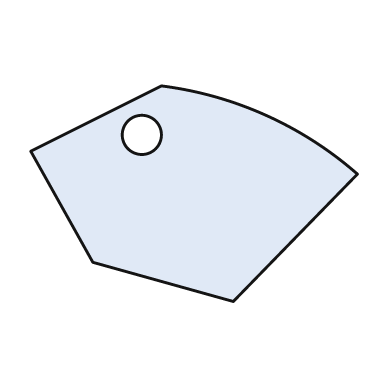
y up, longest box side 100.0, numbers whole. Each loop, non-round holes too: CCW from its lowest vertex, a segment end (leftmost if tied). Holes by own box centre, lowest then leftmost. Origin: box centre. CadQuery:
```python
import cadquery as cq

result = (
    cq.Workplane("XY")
    .moveTo(12.0, -33.0)
    .lineTo(50.0, 6.0)
    .threePointArc((22.0, 24.0), (-10.0, 33.0))
    .lineTo(-50.0, 13.0)
    .lineTo(-31.0, -21.0)
    .close()
    .moveTo(-16.0, 18.0)
    .circle(6.0)
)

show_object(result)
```